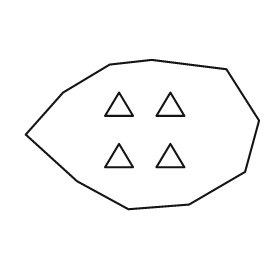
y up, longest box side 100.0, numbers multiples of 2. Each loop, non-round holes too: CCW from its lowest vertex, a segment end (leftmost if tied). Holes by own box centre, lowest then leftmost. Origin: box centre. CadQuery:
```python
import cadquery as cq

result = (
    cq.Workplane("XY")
    .moveTo(-6.0, -32.0)
    .lineTo(20.0, -30.0)
    .lineTo(44.0, -16.0)
    .lineTo(50.0, 6.0)
    .lineTo(36.0, 28.0)
    .lineTo(4.0, 32.0)
    .lineTo(-14.0, 30.0)
    .lineTo(-34.0, 18.0)
    .lineTo(-50.0, 0.0)
    .lineTo(-28.0, -20.0)
    .close()
    .moveTo(-16.0, -14.0)
    .lineTo(-4.0, -14.0)
    .lineTo(-10.0, -4.0)
    .close()
    .moveTo(6.0, -14.0)
    .lineTo(18.0, -14.0)
    .lineTo(12.0, -4.0)
    .close()
    .moveTo(-16.0, 8.0)
    .lineTo(-4.0, 8.0)
    .lineTo(-10.0, 18.0)
    .close()
    .moveTo(6.0, 8.0)
    .lineTo(18.0, 8.0)
    .lineTo(12.0, 18.0)
    .close()
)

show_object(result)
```